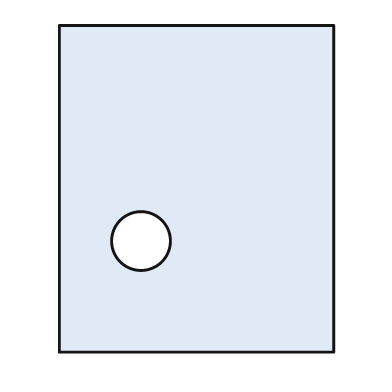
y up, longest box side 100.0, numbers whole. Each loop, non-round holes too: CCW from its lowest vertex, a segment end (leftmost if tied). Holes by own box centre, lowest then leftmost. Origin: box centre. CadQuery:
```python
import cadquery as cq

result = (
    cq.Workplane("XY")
    .moveTo(-42.0, -50.0)
    .lineTo(42.0, -50.0)
    .lineTo(42.0, 50.0)
    .lineTo(-42.0, 50.0)
    .close()
    .moveTo(-17.0, -16.0)
    .circle(9.0)
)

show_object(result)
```